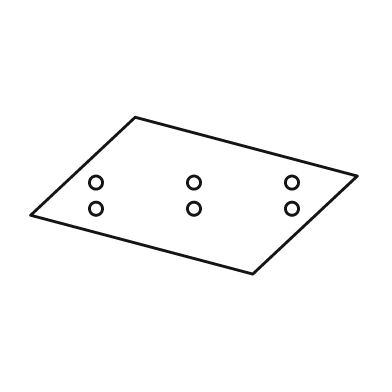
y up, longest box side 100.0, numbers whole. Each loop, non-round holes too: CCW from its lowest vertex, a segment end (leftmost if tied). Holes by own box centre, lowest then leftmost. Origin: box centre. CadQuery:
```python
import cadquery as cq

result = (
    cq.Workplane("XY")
    .moveTo(18.0, -24.0)
    .lineTo(50.0, 6.0)
    .lineTo(-18.0, 24.0)
    .lineTo(-50.0, -6.0)
    .close()
    .moveTo(-30.0, -4.0)
    .circle(2.0)
    .moveTo(0.0, -4.0)
    .circle(2.0)
    .moveTo(30.0, -4.0)
    .circle(2.0)
    .moveTo(-30.0, 4.0)
    .circle(2.0)
    .moveTo(0.0, 4.0)
    .circle(2.0)
    .moveTo(30.0, 4.0)
    .circle(2.0)
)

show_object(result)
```